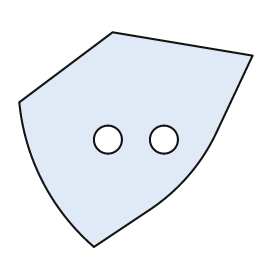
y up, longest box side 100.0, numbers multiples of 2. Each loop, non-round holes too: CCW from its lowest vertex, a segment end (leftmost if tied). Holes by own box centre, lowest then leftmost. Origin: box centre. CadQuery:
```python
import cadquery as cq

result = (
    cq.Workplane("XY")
    .moveTo(-18.0, -46.0)
    .lineTo(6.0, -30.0)
    .threePointArc((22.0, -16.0), (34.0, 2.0))
    .lineTo(50.0, 36.0)
    .lineTo(-10.0, 46.0)
    .lineTo(-50.0, 16.0)
    .threePointArc((-40.0, -18.0), (-18.0, -46.0))
    .close()
    .moveTo(-12.0, 0.0)
    .circle(6.0)
    .moveTo(12.0, 0.0)
    .circle(6.0)
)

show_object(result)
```